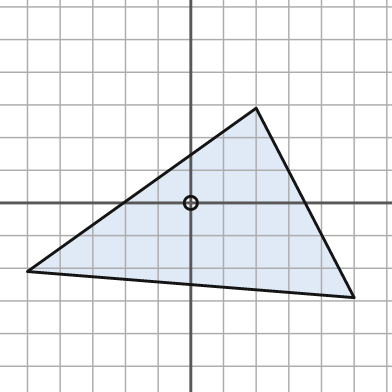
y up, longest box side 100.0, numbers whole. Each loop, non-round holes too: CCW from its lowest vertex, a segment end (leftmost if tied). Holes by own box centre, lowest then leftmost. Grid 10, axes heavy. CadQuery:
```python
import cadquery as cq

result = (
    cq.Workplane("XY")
    .moveTo(50.0, -29.0)
    .lineTo(20.0, 29.0)
    .lineTo(-50.0, -21.0)
    .close()
    .moveTo(0.0, 0.0)
    .circle(2.0)
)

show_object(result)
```